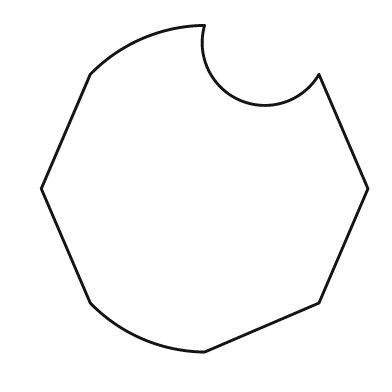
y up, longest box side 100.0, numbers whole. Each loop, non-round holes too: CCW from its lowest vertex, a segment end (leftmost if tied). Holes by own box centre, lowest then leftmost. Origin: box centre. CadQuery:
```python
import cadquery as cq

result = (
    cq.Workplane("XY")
    .moveTo(0.0, -50.0)
    .lineTo(35.0, -35.0)
    .lineTo(50.0, 0.0)
    .lineTo(35.0, 35.0)
    .threePointArc((11.0, 27.0), (0.0, 50.0))
    .threePointArc((-19.0, 46.0), (-35.0, 35.0))
    .lineTo(-50.0, 0.0)
    .lineTo(-35.0, -35.0)
    .threePointArc((-19.0, -46.0), (0.0, -50.0))
    .close()
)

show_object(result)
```